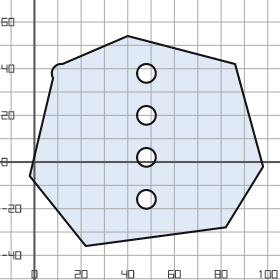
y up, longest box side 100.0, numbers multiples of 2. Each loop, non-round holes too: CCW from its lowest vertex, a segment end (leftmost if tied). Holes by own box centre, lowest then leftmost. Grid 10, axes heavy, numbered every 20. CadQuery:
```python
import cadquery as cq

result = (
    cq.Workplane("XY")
    .moveTo(22.0, -36.0)
    .lineTo(82.0, -28.0)
    .lineTo(98.0, -2.0)
    .lineTo(86.0, 42.0)
    .lineTo(40.0, 54.0)
    .lineTo(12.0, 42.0)
    .threePointArc((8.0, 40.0), (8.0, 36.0))
    .lineTo(-2.0, -6.0)
    .close()
    .moveTo(48.0, -16.0)
    .circle(4.0)
    .moveTo(48.0, 2.0)
    .circle(4.0)
    .moveTo(48.0, 20.0)
    .circle(4.0)
    .moveTo(48.0, 38.0)
    .circle(4.0)
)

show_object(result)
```